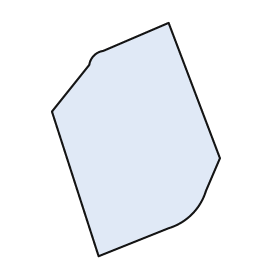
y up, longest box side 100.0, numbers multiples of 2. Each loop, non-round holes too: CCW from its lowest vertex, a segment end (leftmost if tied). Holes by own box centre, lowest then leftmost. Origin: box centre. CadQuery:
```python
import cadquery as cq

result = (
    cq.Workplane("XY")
    .moveTo(-16.0, -50.0)
    .lineTo(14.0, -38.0)
    .threePointArc((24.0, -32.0), (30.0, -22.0))
    .lineTo(36.0, -8.0)
    .lineTo(14.0, 50.0)
    .lineTo(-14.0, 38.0)
    .threePointArc((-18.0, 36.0), (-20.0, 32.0))
    .lineTo(-36.0, 12.0)
    .close()
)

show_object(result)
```